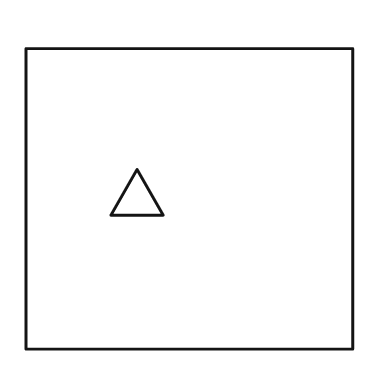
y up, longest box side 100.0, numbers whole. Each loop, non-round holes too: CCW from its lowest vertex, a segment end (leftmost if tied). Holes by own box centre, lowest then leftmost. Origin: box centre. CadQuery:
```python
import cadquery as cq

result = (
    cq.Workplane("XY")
    .moveTo(-50.0, -46.0)
    .lineTo(50.0, -46.0)
    .lineTo(50.0, 46.0)
    .lineTo(-50.0, 46.0)
    .close()
    .moveTo(-24.0, -5.0)
    .lineTo(-8.0, -5.0)
    .lineTo(-16.0, 9.0)
    .close()
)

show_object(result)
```